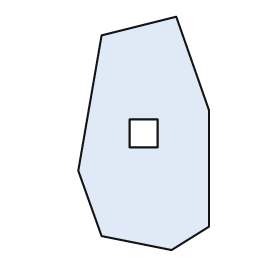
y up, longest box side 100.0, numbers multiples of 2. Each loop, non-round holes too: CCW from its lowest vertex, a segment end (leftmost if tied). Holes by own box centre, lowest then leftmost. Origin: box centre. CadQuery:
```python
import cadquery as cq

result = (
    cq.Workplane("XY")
    .moveTo(12.0, -50.0)
    .lineTo(28.0, -40.0)
    .lineTo(28.0, 10.0)
    .lineTo(14.0, 50.0)
    .lineTo(-18.0, 42.0)
    .lineTo(-28.0, -16.0)
    .lineTo(-18.0, -44.0)
    .close()
    .moveTo(-6.0, -6.0)
    .lineTo(6.0, -6.0)
    .lineTo(6.0, 6.0)
    .lineTo(-6.0, 6.0)
    .close()
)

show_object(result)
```